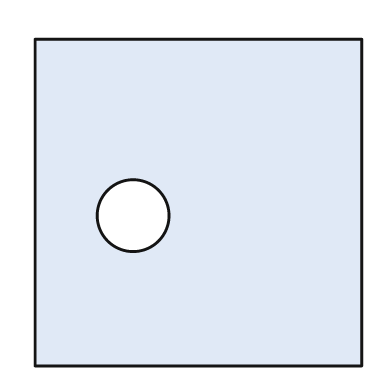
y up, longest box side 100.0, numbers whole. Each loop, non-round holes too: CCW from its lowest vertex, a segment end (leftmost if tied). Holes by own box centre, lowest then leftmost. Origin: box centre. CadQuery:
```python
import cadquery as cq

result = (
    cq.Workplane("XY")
    .moveTo(-50.0, -50.0)
    .lineTo(50.0, -50.0)
    .lineTo(50.0, 50.0)
    .lineTo(-50.0, 50.0)
    .close()
    .moveTo(-20.0, -4.0)
    .circle(11.0)
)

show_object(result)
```